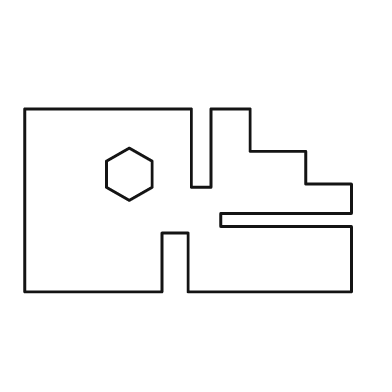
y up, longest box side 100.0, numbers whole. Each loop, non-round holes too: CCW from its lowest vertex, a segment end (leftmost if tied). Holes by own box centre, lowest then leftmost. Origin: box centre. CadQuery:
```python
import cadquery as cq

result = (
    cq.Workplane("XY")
    .moveTo(-50.0, -28.0)
    .lineTo(-8.0, -28.0)
    .lineTo(-8.0, -10.0)
    .lineTo(0.0, -10.0)
    .lineTo(0.0, -28.0)
    .lineTo(50.0, -28.0)
    .lineTo(50.0, -8.0)
    .lineTo(10.0, -8.0)
    .lineTo(10.0, -4.0)
    .lineTo(50.0, -4.0)
    .lineTo(50.0, 5.0)
    .lineTo(36.0, 5.0)
    .lineTo(36.0, 15.0)
    .lineTo(19.0, 15.0)
    .lineTo(19.0, 28.0)
    .lineTo(7.0, 28.0)
    .lineTo(7.0, 4.0)
    .lineTo(1.0, 4.0)
    .lineTo(1.0, 28.0)
    .lineTo(-50.0, 28.0)
    .close()
    .moveTo(-18.0, 0.0)
    .lineTo(-11.0, 4.0)
    .lineTo(-11.0, 12.0)
    .lineTo(-18.0, 16.0)
    .lineTo(-25.0, 12.0)
    .lineTo(-25.0, 4.0)
    .close()
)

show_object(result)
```